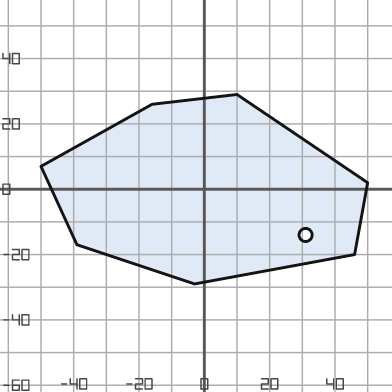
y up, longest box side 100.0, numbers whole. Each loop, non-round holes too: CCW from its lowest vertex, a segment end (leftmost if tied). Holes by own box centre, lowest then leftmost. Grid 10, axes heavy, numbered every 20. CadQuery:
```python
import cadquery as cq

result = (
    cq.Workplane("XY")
    .moveTo(-3.0, -29.0)
    .lineTo(46.0, -20.0)
    .lineTo(50.0, 2.0)
    .lineTo(10.0, 29.0)
    .lineTo(-16.0, 26.0)
    .lineTo(-50.0, 7.0)
    .lineTo(-39.0, -17.0)
    .close()
    .moveTo(31.0, -14.0)
    .circle(2.0)
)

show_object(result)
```